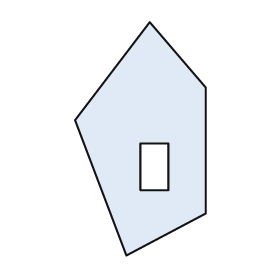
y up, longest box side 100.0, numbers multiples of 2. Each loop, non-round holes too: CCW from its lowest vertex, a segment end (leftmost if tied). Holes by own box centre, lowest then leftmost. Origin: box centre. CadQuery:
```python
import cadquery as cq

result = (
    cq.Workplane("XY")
    .moveTo(-6.0, -50.0)
    .lineTo(28.0, -32.0)
    .lineTo(28.0, 22.0)
    .lineTo(4.0, 50.0)
    .lineTo(-28.0, 8.0)
    .close()
    .moveTo(0.0, -22.0)
    .lineTo(12.0, -22.0)
    .lineTo(12.0, -2.0)
    .lineTo(0.0, -2.0)
    .close()
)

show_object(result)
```